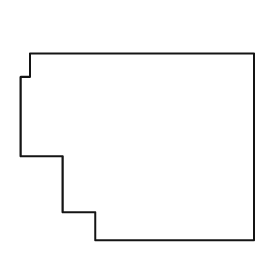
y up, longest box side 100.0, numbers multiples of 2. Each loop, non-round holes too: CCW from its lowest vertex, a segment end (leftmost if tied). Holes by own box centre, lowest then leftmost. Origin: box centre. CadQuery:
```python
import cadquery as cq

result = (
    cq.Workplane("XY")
    .moveTo(-18.0, -40.0)
    .lineTo(50.0, -40.0)
    .lineTo(50.0, 40.0)
    .lineTo(-46.0, 40.0)
    .lineTo(-46.0, 30.0)
    .lineTo(-50.0, 30.0)
    .lineTo(-50.0, -4.0)
    .lineTo(-32.0, -4.0)
    .lineTo(-32.0, -28.0)
    .lineTo(-18.0, -28.0)
    .close()
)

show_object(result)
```